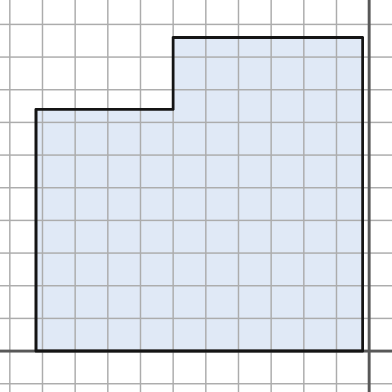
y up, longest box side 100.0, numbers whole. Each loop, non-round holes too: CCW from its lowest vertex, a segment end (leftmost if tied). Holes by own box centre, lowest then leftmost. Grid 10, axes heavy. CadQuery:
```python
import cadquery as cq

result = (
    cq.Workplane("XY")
    .moveTo(-102.0, 0.0)
    .lineTo(-2.0, 0.0)
    .lineTo(-2.0, 96.0)
    .lineTo(-60.0, 96.0)
    .lineTo(-60.0, 74.0)
    .lineTo(-102.0, 74.0)
    .close()
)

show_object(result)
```